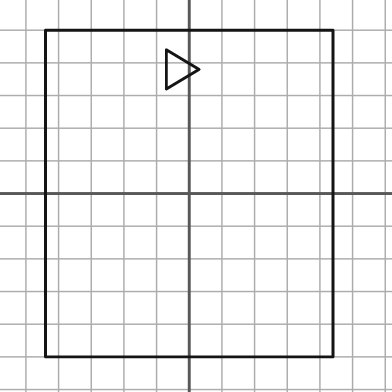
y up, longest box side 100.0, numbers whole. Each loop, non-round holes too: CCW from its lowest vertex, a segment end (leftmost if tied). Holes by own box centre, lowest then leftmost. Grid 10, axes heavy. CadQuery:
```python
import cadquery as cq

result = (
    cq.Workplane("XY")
    .moveTo(-44.0, -50.0)
    .lineTo(44.0, -50.0)
    .lineTo(44.0, 50.0)
    .lineTo(-44.0, 50.0)
    .close()
    .moveTo(-7.0, 32.0)
    .lineTo(3.0, 38.0)
    .lineTo(-7.0, 44.0)
    .close()
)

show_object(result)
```